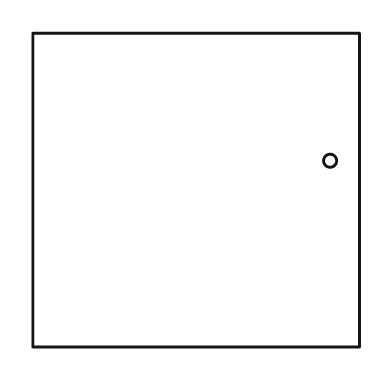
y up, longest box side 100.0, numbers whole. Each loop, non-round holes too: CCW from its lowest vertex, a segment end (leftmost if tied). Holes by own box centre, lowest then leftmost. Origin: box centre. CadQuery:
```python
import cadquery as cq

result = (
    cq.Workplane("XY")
    .moveTo(-50.0, -48.0)
    .lineTo(50.0, -48.0)
    .lineTo(50.0, 48.0)
    .lineTo(-50.0, 48.0)
    .close()
    .moveTo(41.0, 9.0)
    .circle(2.0)
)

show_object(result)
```